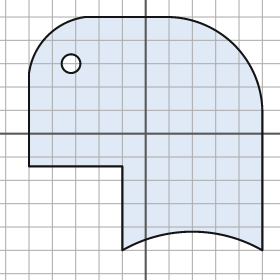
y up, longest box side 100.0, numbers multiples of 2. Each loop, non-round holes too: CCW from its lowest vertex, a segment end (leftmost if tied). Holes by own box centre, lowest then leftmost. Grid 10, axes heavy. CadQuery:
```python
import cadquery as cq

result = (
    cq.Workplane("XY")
    .moveTo(-10.0, -50.0)
    .threePointArc((20.0, -42.0), (50.0, -50.0))
    .lineTo(50.0, 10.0)
    .threePointArc((38.0, 38.0), (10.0, 50.0))
    .lineTo(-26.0, 50.0)
    .threePointArc((-42.0, 42.0), (-50.0, 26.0))
    .lineTo(-50.0, -14.0)
    .lineTo(-10.0, -14.0)
    .close()
    .moveTo(-32.0, 30.0)
    .circle(4.0)
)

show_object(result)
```